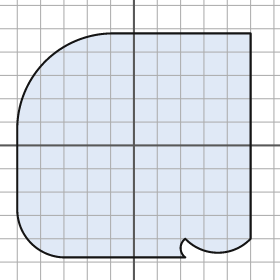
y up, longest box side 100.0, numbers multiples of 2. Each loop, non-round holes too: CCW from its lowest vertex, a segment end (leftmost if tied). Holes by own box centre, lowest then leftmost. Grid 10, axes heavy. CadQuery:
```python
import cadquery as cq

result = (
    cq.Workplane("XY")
    .moveTo(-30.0, -48.0)
    .lineTo(22.0, -48.0)
    .threePointArc((20.0, -44.0), (22.0, -40.0))
    .threePointArc((36.0, -46.0), (50.0, -40.0))
    .lineTo(50.0, 48.0)
    .lineTo(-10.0, 48.0)
    .threePointArc((-38.0, 36.0), (-50.0, 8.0))
    .lineTo(-50.0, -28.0)
    .threePointArc((-44.0, -42.0), (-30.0, -48.0))
    .close()
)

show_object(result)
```